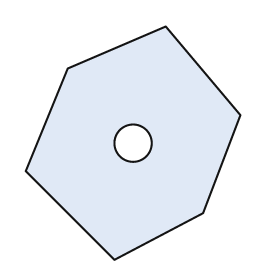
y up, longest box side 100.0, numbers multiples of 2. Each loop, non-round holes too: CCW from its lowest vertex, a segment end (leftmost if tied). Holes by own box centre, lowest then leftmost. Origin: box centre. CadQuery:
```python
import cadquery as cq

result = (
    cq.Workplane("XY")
    .moveTo(-8.0, -50.0)
    .lineTo(30.0, -30.0)
    .lineTo(46.0, 12.0)
    .lineTo(14.0, 50.0)
    .lineTo(-28.0, 32.0)
    .lineTo(-46.0, -12.0)
    .close()
    .moveTo(0.0, 0.0)
    .circle(8.0)
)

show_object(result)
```